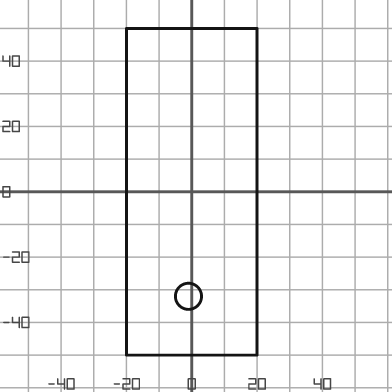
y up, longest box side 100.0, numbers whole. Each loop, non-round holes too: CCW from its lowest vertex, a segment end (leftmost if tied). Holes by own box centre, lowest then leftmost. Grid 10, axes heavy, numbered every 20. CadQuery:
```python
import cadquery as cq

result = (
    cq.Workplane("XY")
    .moveTo(-20.0, -50.0)
    .lineTo(20.0, -50.0)
    .lineTo(20.0, 50.0)
    .lineTo(-20.0, 50.0)
    .close()
    .moveTo(-1.0, -32.0)
    .circle(4.0)
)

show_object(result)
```